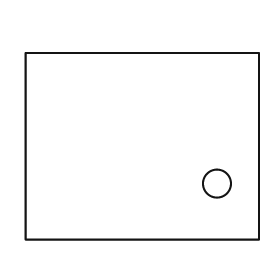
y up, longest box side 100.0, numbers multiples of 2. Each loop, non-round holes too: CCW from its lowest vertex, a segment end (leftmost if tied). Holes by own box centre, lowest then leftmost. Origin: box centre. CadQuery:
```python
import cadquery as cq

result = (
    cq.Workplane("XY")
    .moveTo(-50.0, -40.0)
    .lineTo(50.0, -40.0)
    .lineTo(50.0, 40.0)
    .lineTo(-50.0, 40.0)
    .close()
    .moveTo(32.0, -16.0)
    .circle(6.0)
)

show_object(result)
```